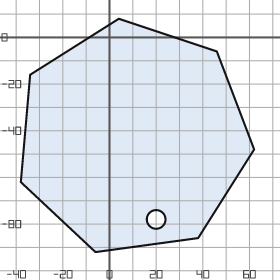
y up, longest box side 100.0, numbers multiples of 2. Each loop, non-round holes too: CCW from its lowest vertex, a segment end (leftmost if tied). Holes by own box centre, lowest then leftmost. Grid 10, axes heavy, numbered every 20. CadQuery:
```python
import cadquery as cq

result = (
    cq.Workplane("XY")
    .moveTo(-6.0, -92.0)
    .lineTo(38.0, -86.0)
    .lineTo(62.0, -48.0)
    .lineTo(46.0, -6.0)
    .lineTo(4.0, 8.0)
    .lineTo(-34.0, -16.0)
    .lineTo(-38.0, -62.0)
    .close()
    .moveTo(20.0, -78.0)
    .circle(4.0)
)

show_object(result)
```